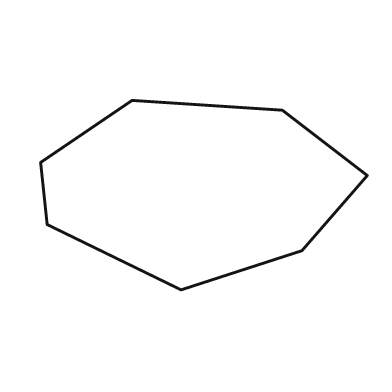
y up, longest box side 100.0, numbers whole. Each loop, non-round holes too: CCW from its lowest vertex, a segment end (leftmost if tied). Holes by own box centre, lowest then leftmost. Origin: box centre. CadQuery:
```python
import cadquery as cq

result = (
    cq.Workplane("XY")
    .moveTo(-7.0, -29.0)
    .lineTo(30.0, -17.0)
    .lineTo(50.0, 6.0)
    .lineTo(24.0, 26.0)
    .lineTo(-22.0, 29.0)
    .lineTo(-50.0, 10.0)
    .lineTo(-48.0, -9.0)
    .close()
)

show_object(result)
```